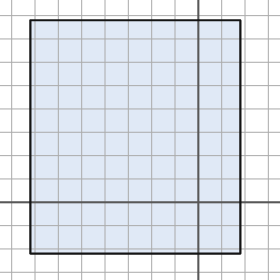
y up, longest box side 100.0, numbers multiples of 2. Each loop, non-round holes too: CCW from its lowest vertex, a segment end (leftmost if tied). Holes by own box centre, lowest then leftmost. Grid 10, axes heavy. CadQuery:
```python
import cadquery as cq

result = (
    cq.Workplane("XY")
    .moveTo(-72.0, -22.0)
    .lineTo(18.0, -22.0)
    .lineTo(18.0, 78.0)
    .lineTo(-72.0, 78.0)
    .close()
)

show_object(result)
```